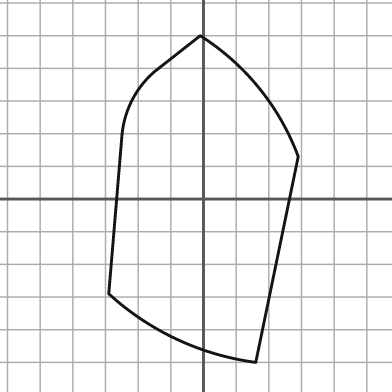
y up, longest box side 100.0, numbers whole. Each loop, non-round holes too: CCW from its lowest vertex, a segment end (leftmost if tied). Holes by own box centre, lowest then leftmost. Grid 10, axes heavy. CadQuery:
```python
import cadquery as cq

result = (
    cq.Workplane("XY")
    .moveTo(16.0, -50.0)
    .lineTo(29.0, 13.0)
    .threePointArc((17.0, 34.0), (-1.0, 50.0))
    .lineTo(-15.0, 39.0)
    .threePointArc((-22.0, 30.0), (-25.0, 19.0))
    .lineTo(-29.0, -29.0)
    .threePointArc((-8.0, -43.0), (16.0, -50.0))
    .close()
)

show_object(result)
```